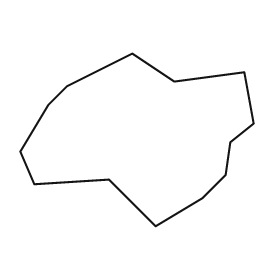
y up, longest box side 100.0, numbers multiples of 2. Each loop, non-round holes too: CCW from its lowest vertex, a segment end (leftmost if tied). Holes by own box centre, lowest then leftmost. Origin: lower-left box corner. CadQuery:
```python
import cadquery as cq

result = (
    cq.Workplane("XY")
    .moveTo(58.0, 0.0)
    .lineTo(78.0, 12.0)
    .lineTo(88.0, 22.0)
    .lineTo(90.0, 36.0)
    .lineTo(100.0, 44.0)
    .lineTo(96.0, 66.0)
    .lineTo(66.0, 62.0)
    .lineTo(48.0, 74.0)
    .lineTo(20.0, 60.0)
    .lineTo(12.0, 52.0)
    .lineTo(0.0, 32.0)
    .lineTo(6.0, 18.0)
    .lineTo(38.0, 20.0)
    .close()
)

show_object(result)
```